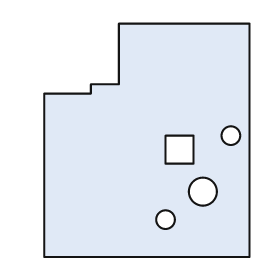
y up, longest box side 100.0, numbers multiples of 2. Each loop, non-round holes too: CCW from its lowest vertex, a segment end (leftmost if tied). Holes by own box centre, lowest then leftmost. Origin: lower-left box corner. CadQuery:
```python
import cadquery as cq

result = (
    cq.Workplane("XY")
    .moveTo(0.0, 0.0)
    .lineTo(88.0, 0.0)
    .lineTo(88.0, 100.0)
    .lineTo(32.0, 100.0)
    .lineTo(32.0, 74.0)
    .lineTo(20.0, 74.0)
    .lineTo(20.0, 70.0)
    .lineTo(0.0, 70.0)
    .close()
    .moveTo(52.0, 16.0)
    .circle(4.0)
    .moveTo(68.0, 28.0)
    .circle(6.0)
    .moveTo(52.0, 40.0)
    .lineTo(64.0, 40.0)
    .lineTo(64.0, 52.0)
    .lineTo(52.0, 52.0)
    .close()
    .moveTo(80.0, 52.0)
    .circle(4.0)
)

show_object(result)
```